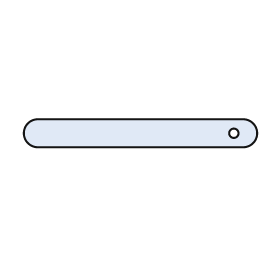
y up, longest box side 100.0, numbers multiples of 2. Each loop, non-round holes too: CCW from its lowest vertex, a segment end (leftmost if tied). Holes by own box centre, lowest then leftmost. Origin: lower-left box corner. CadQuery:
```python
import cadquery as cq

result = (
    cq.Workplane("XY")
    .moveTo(6.0, 0.0)
    .lineTo(94.0, 0.0)
    .threePointArc((100.0, 6.0), (94.0, 12.0))
    .lineTo(6.0, 12.0)
    .threePointArc((0.0, 6.0), (6.0, 0.0))
    .close()
    .moveTo(90.0, 6.0)
    .circle(2.0)
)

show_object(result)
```